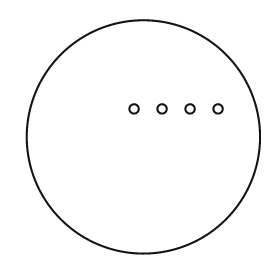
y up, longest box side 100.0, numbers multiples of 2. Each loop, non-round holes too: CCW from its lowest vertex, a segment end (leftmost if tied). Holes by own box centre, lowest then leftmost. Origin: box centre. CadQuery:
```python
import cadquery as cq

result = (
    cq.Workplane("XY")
    .moveTo(0.0, 0.0)
    .circle(50.0)
    .moveTo(-4.0, 12.0)
    .circle(2.0)
    .moveTo(8.0, 12.0)
    .circle(2.0)
    .moveTo(20.0, 12.0)
    .circle(2.0)
    .moveTo(32.0, 12.0)
    .circle(2.0)
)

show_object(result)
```